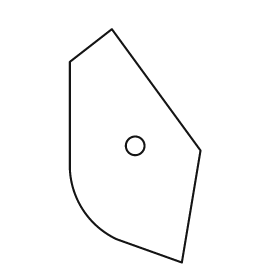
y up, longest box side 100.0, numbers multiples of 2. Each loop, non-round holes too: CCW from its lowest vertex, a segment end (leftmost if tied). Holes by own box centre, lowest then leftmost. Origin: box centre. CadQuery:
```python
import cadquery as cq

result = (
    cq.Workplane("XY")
    .moveTo(20.0, -50.0)
    .lineTo(28.0, -2.0)
    .lineTo(-10.0, 50.0)
    .lineTo(-28.0, 36.0)
    .lineTo(-28.0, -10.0)
    .threePointArc((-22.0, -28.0), (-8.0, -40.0))
    .close()
    .moveTo(0.0, 0.0)
    .circle(4.0)
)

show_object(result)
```